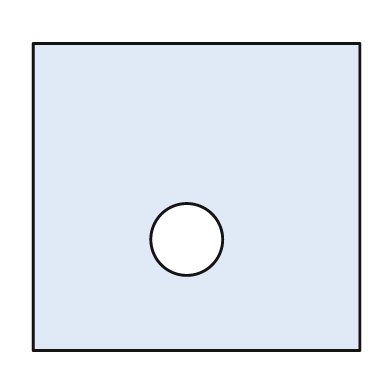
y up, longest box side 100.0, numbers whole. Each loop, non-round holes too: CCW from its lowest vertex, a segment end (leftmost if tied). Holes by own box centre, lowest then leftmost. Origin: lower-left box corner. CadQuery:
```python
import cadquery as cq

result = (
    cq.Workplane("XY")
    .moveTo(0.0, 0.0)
    .lineTo(100.0, 0.0)
    .lineTo(100.0, 94.0)
    .lineTo(0.0, 94.0)
    .close()
    .moveTo(47.0, 34.0)
    .circle(11.0)
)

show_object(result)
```